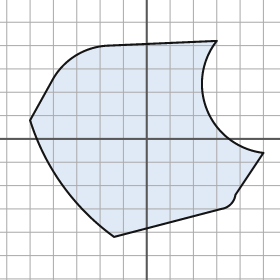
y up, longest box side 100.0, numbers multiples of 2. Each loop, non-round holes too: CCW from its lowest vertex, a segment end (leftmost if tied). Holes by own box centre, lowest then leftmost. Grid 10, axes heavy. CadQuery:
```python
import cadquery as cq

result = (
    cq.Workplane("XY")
    .moveTo(-14.0, -42.0)
    .lineTo(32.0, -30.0)
    .threePointArc((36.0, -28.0), (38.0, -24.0))
    .lineTo(50.0, -6.0)
    .threePointArc((26.0, 12.0), (30.0, 42.0))
    .lineTo(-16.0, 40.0)
    .threePointArc((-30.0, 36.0), (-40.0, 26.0))
    .lineTo(-50.0, 8.0)
    .threePointArc((-36.0, -20.0), (-14.0, -42.0))
    .close()
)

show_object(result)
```